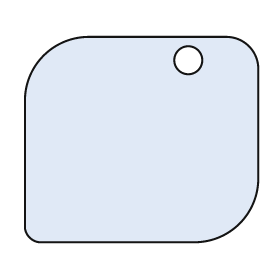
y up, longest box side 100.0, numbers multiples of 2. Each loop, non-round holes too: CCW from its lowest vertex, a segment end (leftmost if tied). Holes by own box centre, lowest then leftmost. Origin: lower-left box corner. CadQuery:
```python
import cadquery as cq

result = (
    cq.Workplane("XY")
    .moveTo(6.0, 0.0)
    .lineTo(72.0, 0.0)
    .threePointArc((92.0, 8.0), (100.0, 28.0))
    .lineTo(100.0, 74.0)
    .threePointArc((96.0, 84.0), (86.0, 88.0))
    .lineTo(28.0, 88.0)
    .threePointArc((8.0, 80.0), (0.0, 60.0))
    .lineTo(0.0, 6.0)
    .threePointArc((2.0, 2.0), (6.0, 0.0))
    .close()
    .moveTo(70.0, 78.0)
    .circle(6.0)
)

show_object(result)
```